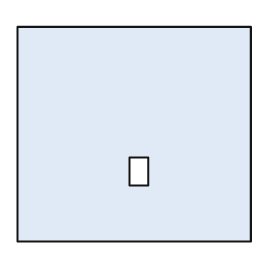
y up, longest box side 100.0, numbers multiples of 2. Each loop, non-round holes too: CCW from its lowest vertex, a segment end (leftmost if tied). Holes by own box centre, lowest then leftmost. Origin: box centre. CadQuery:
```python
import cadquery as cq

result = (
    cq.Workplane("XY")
    .moveTo(-50.0, -46.0)
    .lineTo(50.0, -46.0)
    .lineTo(50.0, 46.0)
    .lineTo(-50.0, 46.0)
    .close()
    .moveTo(-2.0, -22.0)
    .lineTo(6.0, -22.0)
    .lineTo(6.0, -10.0)
    .lineTo(-2.0, -10.0)
    .close()
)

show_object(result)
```